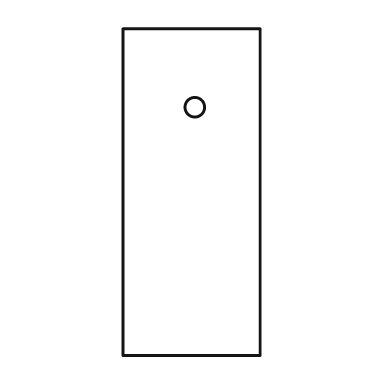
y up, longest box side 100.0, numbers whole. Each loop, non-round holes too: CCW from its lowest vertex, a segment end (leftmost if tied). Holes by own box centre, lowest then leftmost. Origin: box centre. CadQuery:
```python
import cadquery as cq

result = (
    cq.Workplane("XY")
    .moveTo(-21.0, -50.0)
    .lineTo(21.0, -50.0)
    .lineTo(21.0, 50.0)
    .lineTo(-21.0, 50.0)
    .close()
    .moveTo(1.0, 26.0)
    .circle(3.0)
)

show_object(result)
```